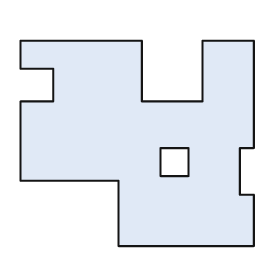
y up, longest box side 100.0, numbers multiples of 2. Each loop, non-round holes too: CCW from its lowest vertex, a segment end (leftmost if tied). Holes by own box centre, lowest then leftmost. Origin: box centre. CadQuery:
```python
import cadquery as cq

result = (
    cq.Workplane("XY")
    .moveTo(-8.0, -44.0)
    .lineTo(50.0, -44.0)
    .lineTo(50.0, -22.0)
    .lineTo(44.0, -22.0)
    .lineTo(44.0, -2.0)
    .lineTo(50.0, -2.0)
    .lineTo(50.0, 44.0)
    .lineTo(28.0, 44.0)
    .lineTo(28.0, 18.0)
    .lineTo(2.0, 18.0)
    .lineTo(2.0, 44.0)
    .lineTo(-50.0, 44.0)
    .lineTo(-50.0, 32.0)
    .lineTo(-36.0, 32.0)
    .lineTo(-36.0, 18.0)
    .lineTo(-50.0, 18.0)
    .lineTo(-50.0, -16.0)
    .lineTo(-8.0, -16.0)
    .close()
    .moveTo(10.0, -14.0)
    .lineTo(22.0, -14.0)
    .lineTo(22.0, -2.0)
    .lineTo(10.0, -2.0)
    .close()
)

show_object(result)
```